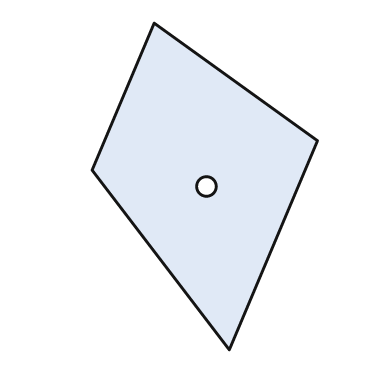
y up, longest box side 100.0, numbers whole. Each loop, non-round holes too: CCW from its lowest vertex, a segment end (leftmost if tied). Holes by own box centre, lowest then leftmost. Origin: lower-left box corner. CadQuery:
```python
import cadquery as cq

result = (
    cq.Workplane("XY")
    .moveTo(42.0, 0.0)
    .lineTo(69.0, 64.0)
    .lineTo(19.0, 100.0)
    .lineTo(0.0, 55.0)
    .close()
    .moveTo(35.0, 50.0)
    .circle(3.0)
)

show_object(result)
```